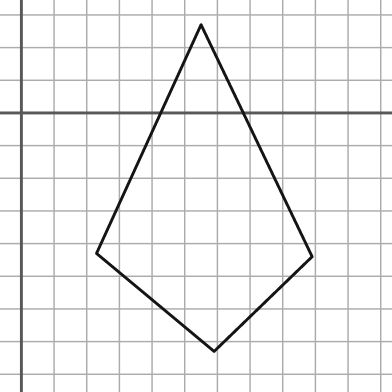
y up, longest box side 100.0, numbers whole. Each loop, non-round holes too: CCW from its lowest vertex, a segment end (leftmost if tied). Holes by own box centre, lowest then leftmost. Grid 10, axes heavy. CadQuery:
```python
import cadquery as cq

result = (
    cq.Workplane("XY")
    .moveTo(59.0, -73.0)
    .lineTo(89.0, -44.0)
    .lineTo(55.0, 27.0)
    .lineTo(23.0, -43.0)
    .close()
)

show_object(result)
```